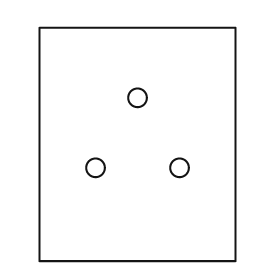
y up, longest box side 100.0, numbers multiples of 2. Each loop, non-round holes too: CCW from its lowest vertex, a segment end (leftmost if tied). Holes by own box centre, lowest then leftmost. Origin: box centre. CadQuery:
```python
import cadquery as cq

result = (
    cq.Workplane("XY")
    .moveTo(-42.0, -50.0)
    .lineTo(42.0, -50.0)
    .lineTo(42.0, 50.0)
    .lineTo(-42.0, 50.0)
    .close()
    .moveTo(-18.0, -10.0)
    .circle(4.0)
    .moveTo(18.0, -10.0)
    .circle(4.0)
    .moveTo(0.0, 20.0)
    .circle(4.0)
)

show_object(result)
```